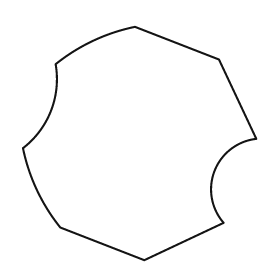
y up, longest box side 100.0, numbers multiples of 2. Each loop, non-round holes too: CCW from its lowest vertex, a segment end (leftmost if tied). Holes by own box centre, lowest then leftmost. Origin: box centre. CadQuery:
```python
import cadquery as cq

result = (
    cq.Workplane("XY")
    .moveTo(2.0, -50.0)
    .lineTo(36.0, -34.0)
    .threePointArc((32.0, -12.0), (50.0, 2.0))
    .lineTo(34.0, 36.0)
    .lineTo(-2.0, 50.0)
    .threePointArc((-20.0, 44.0), (-36.0, 34.0))
    .threePointArc((-38.0, 14.0), (-50.0, -2.0))
    .threePointArc((-44.0, -20.0), (-34.0, -36.0))
    .close()
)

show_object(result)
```